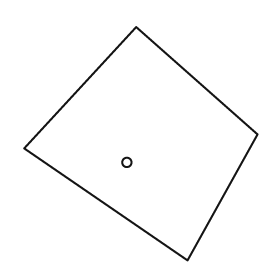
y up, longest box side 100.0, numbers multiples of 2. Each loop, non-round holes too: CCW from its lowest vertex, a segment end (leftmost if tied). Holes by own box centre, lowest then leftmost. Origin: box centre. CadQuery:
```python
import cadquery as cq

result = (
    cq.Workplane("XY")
    .moveTo(20.0, -50.0)
    .lineTo(50.0, 4.0)
    .lineTo(-2.0, 50.0)
    .lineTo(-50.0, -2.0)
    .close()
    .moveTo(-6.0, -8.0)
    .circle(2.0)
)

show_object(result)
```